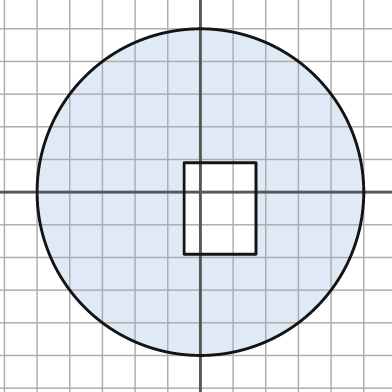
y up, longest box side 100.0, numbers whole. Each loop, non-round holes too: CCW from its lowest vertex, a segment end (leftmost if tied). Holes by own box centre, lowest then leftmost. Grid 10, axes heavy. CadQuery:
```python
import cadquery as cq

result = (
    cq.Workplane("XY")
    .moveTo(0.0, 0.0)
    .circle(50.0)
    .moveTo(-5.0, -19.0)
    .lineTo(17.0, -19.0)
    .lineTo(17.0, 9.0)
    .lineTo(-5.0, 9.0)
    .close()
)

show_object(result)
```